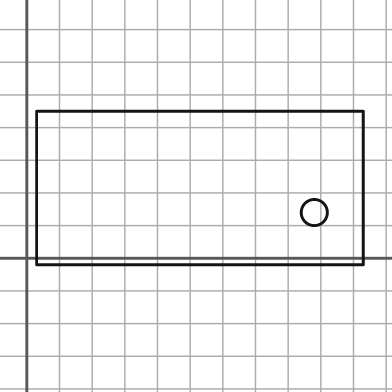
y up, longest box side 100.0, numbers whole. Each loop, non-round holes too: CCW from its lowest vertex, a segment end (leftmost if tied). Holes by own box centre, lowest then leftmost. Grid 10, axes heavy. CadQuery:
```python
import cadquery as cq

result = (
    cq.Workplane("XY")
    .moveTo(3.0, -2.0)
    .lineTo(103.0, -2.0)
    .lineTo(103.0, 45.0)
    .lineTo(3.0, 45.0)
    .close()
    .moveTo(88.0, 14.0)
    .circle(4.0)
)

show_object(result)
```